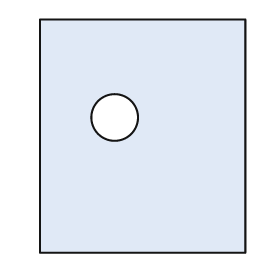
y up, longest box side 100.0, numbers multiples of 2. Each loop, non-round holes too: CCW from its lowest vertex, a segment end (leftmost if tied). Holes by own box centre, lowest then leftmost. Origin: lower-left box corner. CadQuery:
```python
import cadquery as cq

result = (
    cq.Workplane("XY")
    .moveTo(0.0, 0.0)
    .lineTo(88.0, 0.0)
    .lineTo(88.0, 100.0)
    .lineTo(0.0, 100.0)
    .close()
    .moveTo(32.0, 58.0)
    .circle(10.0)
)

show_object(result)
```